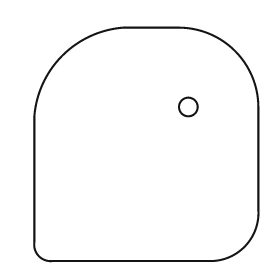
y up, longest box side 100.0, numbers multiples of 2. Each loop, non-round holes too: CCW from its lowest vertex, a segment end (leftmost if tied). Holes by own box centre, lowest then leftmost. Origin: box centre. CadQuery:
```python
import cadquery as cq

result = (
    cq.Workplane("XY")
    .moveTo(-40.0, -50.0)
    .lineTo(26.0, -50.0)
    .threePointArc((42.0, -44.0), (48.0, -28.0))
    .lineTo(48.0, 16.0)
    .threePointArc((38.0, 40.0), (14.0, 50.0))
    .lineTo(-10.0, 50.0)
    .threePointArc((-36.0, 38.0), (-48.0, 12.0))
    .lineTo(-48.0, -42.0)
    .threePointArc((-46.0, -48.0), (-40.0, -50.0))
    .close()
    .moveTo(18.0, 16.0)
    .circle(4.0)
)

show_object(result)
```